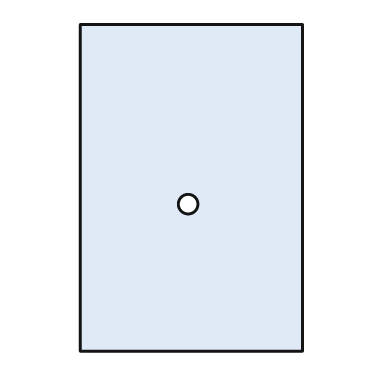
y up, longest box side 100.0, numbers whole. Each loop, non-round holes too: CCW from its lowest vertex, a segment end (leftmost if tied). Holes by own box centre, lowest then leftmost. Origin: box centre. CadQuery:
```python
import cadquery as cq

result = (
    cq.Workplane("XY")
    .moveTo(-34.0, -50.0)
    .lineTo(34.0, -50.0)
    .lineTo(34.0, 50.0)
    .lineTo(-34.0, 50.0)
    .close()
    .moveTo(-1.0, -5.0)
    .circle(3.0)
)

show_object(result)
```